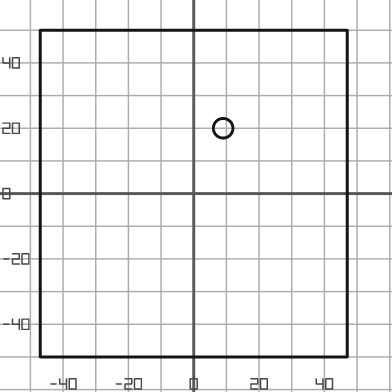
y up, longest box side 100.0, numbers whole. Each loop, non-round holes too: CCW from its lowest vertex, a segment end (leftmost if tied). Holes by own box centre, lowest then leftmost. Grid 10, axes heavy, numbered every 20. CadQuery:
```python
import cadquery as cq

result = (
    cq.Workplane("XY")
    .moveTo(-47.0, -50.0)
    .lineTo(47.0, -50.0)
    .lineTo(47.0, 50.0)
    .lineTo(-47.0, 50.0)
    .close()
    .moveTo(9.0, 20.0)
    .circle(3.0)
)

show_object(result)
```